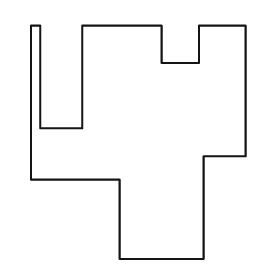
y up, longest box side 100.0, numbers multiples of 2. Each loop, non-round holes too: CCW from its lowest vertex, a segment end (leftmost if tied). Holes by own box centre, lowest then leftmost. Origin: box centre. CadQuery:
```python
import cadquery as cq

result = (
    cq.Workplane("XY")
    .moveTo(-8.0, -50.0)
    .lineTo(28.0, -50.0)
    .lineTo(28.0, -6.0)
    .lineTo(46.0, -6.0)
    .lineTo(46.0, 50.0)
    .lineTo(26.0, 50.0)
    .lineTo(26.0, 34.0)
    .lineTo(10.0, 34.0)
    .lineTo(10.0, 50.0)
    .lineTo(-24.0, 50.0)
    .lineTo(-24.0, 6.0)
    .lineTo(-42.0, 6.0)
    .lineTo(-42.0, 50.0)
    .lineTo(-46.0, 50.0)
    .lineTo(-46.0, -16.0)
    .lineTo(-8.0, -16.0)
    .close()
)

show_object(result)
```